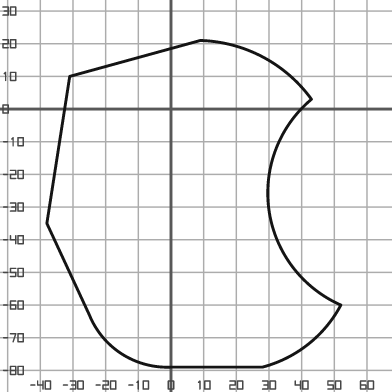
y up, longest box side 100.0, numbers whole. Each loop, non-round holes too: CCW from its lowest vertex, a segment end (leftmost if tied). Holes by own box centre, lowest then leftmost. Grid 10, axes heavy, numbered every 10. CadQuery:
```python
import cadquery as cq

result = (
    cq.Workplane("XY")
    .moveTo(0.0, -79.0)
    .lineTo(28.0, -79.0)
    .threePointArc((42.0, -72.0), (52.0, -60.0))
    .threePointArc((30.0, -31.0), (43.0, 3.0))
    .threePointArc((28.0, 16.0), (9.0, 21.0))
    .lineTo(-31.0, 10.0)
    .lineTo(-38.0, -35.0)
    .lineTo(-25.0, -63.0)
    .threePointArc((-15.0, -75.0), (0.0, -79.0))
    .close()
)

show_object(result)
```